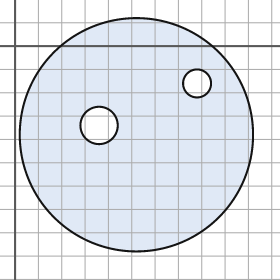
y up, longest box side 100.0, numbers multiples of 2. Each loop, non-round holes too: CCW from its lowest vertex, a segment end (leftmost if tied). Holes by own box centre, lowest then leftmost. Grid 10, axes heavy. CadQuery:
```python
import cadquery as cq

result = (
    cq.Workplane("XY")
    .moveTo(52.0, -38.0)
    .circle(50.0)
    .moveTo(36.0, -34.0)
    .circle(8.0)
    .moveTo(78.0, -16.0)
    .circle(6.0)
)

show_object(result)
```